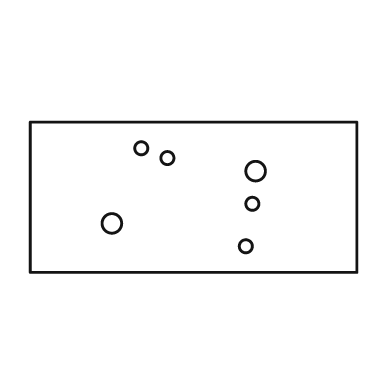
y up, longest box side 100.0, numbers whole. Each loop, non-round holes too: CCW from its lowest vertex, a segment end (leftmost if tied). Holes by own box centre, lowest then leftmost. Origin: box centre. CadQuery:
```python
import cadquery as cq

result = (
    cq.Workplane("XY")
    .moveTo(-50.0, -23.0)
    .lineTo(50.0, -23.0)
    .lineTo(50.0, 23.0)
    .lineTo(-50.0, 23.0)
    .close()
    .moveTo(16.0, -15.0)
    .circle(2.0)
    .moveTo(-25.0, -8.0)
    .circle(3.0)
    .moveTo(18.0, -2.0)
    .circle(2.0)
    .moveTo(19.0, 8.0)
    .circle(3.0)
    .moveTo(-8.0, 12.0)
    .circle(2.0)
    .moveTo(-16.0, 15.0)
    .circle(2.0)
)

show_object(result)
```